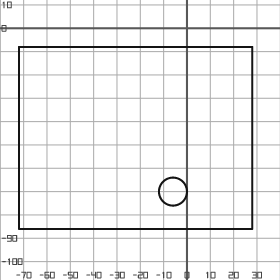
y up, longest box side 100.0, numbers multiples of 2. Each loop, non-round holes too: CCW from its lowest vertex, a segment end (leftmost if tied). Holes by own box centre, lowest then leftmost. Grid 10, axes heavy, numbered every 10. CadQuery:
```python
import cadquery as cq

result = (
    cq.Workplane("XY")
    .moveTo(-72.0, -86.0)
    .lineTo(28.0, -86.0)
    .lineTo(28.0, -8.0)
    .lineTo(-72.0, -8.0)
    .close()
    .moveTo(-6.0, -70.0)
    .circle(6.0)
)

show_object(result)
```